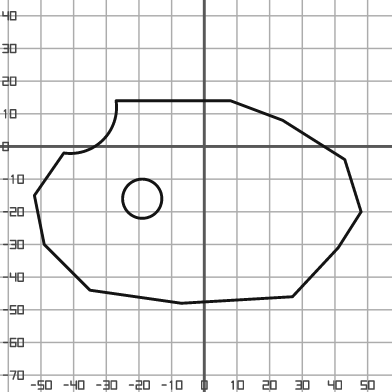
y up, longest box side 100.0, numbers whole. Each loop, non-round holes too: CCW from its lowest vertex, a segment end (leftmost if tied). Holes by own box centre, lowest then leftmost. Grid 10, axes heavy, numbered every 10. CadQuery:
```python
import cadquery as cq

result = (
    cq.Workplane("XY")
    .moveTo(-7.0, -48.0)
    .lineTo(27.0, -46.0)
    .lineTo(41.0, -31.0)
    .lineTo(48.0, -20.0)
    .lineTo(43.0, -4.0)
    .lineTo(24.0, 8.0)
    .lineTo(8.0, 14.0)
    .lineTo(-27.0, 14.0)
    .threePointArc((-31.0, 2.0), (-43.0, -2.0))
    .lineTo(-52.0, -15.0)
    .lineTo(-49.0, -30.0)
    .lineTo(-35.0, -44.0)
    .close()
    .moveTo(-19.0, -16.0)
    .circle(6.0)
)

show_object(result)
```